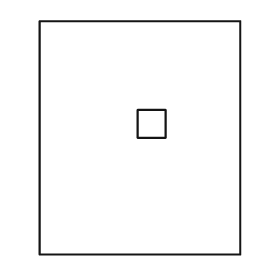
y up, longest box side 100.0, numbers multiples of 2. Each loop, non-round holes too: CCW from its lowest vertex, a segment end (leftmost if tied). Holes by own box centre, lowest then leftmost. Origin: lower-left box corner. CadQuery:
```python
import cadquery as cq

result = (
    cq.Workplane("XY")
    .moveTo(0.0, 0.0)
    .lineTo(86.0, 0.0)
    .lineTo(86.0, 100.0)
    .lineTo(0.0, 100.0)
    .close()
    .moveTo(42.0, 50.0)
    .lineTo(54.0, 50.0)
    .lineTo(54.0, 62.0)
    .lineTo(42.0, 62.0)
    .close()
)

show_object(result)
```